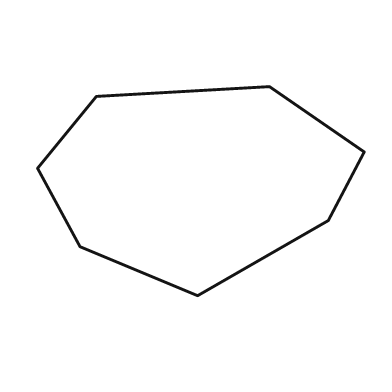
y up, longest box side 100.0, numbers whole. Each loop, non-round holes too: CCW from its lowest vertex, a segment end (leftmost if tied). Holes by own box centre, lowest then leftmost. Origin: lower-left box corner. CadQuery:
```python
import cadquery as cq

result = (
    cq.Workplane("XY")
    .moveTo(49.0, 0.0)
    .lineTo(89.0, 23.0)
    .lineTo(100.0, 44.0)
    .lineTo(71.0, 64.0)
    .lineTo(18.0, 61.0)
    .lineTo(0.0, 39.0)
    .lineTo(13.0, 15.0)
    .close()
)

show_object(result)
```